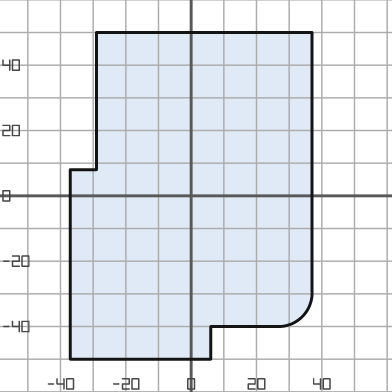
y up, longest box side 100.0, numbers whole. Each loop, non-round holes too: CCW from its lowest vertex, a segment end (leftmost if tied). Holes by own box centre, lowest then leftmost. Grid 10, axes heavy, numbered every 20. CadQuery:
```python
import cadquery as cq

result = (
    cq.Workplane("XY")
    .moveTo(-37.0, -50.0)
    .lineTo(6.0, -50.0)
    .lineTo(6.0, -40.0)
    .lineTo(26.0, -40.0)
    .threePointArc((34.0, -37.0), (37.0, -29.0))
    .lineTo(37.0, 50.0)
    .lineTo(-29.0, 50.0)
    .lineTo(-29.0, 8.0)
    .lineTo(-37.0, 8.0)
    .close()
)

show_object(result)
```